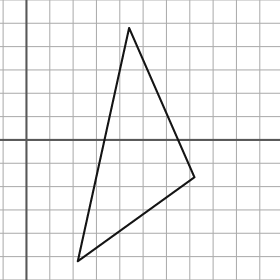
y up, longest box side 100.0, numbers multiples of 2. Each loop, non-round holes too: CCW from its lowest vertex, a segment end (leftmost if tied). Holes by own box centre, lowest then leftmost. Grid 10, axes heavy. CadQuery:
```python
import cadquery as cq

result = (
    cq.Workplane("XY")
    .moveTo(22.0, -52.0)
    .lineTo(72.0, -16.0)
    .lineTo(44.0, 48.0)
    .close()
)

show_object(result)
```